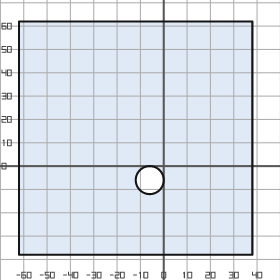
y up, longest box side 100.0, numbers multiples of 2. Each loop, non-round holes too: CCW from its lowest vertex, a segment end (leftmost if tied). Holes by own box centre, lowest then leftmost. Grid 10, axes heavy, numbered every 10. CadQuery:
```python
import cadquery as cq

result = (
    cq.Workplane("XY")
    .moveTo(-62.0, -38.0)
    .lineTo(38.0, -38.0)
    .lineTo(38.0, 62.0)
    .lineTo(-62.0, 62.0)
    .close()
    .moveTo(-6.0, -6.0)
    .circle(6.0)
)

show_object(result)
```